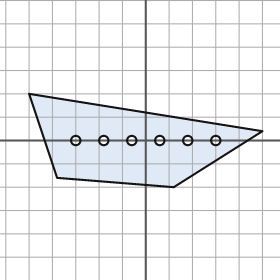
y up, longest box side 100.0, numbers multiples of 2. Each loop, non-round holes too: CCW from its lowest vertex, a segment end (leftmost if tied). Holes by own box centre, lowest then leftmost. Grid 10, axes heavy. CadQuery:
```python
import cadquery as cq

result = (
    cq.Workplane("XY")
    .moveTo(12.0, -20.0)
    .lineTo(50.0, 4.0)
    .lineTo(-50.0, 20.0)
    .lineTo(-38.0, -16.0)
    .close()
    .moveTo(-30.0, 0.0)
    .circle(2.0)
    .moveTo(-18.0, 0.0)
    .circle(2.0)
    .moveTo(-6.0, 0.0)
    .circle(2.0)
    .moveTo(6.0, 0.0)
    .circle(2.0)
    .moveTo(18.0, 0.0)
    .circle(2.0)
    .moveTo(30.0, 0.0)
    .circle(2.0)
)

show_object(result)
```